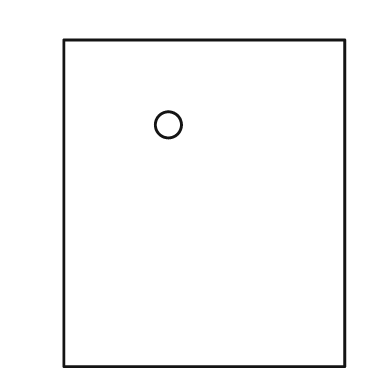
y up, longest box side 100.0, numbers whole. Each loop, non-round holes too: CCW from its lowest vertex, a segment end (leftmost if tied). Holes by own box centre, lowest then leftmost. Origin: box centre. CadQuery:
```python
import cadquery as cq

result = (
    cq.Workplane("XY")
    .moveTo(-43.0, -50.0)
    .lineTo(43.0, -50.0)
    .lineTo(43.0, 50.0)
    .lineTo(-43.0, 50.0)
    .close()
    .moveTo(-11.0, 24.0)
    .circle(4.0)
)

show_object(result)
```